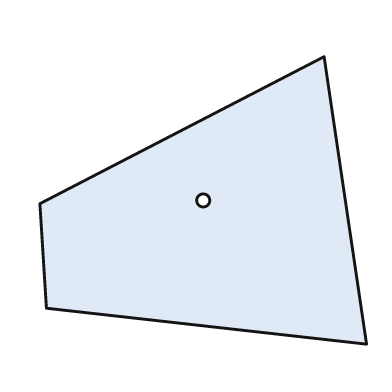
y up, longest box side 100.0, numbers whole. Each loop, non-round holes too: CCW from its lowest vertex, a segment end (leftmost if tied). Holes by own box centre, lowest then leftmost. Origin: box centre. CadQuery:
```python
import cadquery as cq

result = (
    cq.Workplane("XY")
    .moveTo(50.0, -44.0)
    .lineTo(37.0, 44.0)
    .lineTo(-50.0, -1.0)
    .lineTo(-48.0, -33.0)
    .close()
    .moveTo(0.0, 0.0)
    .circle(2.0)
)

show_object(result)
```